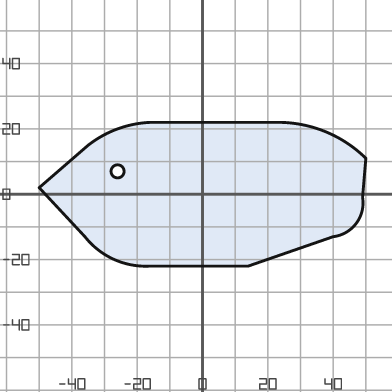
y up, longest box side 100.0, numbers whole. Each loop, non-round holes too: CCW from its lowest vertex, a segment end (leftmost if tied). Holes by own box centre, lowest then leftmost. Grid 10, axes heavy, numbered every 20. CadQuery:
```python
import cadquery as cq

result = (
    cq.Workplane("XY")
    .moveTo(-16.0, -22.0)
    .lineTo(14.0, -22.0)
    .lineTo(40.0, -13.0)
    .threePointArc((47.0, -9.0), (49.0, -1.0))
    .lineTo(50.0, 11.0)
    .threePointArc((38.0, 19.0), (24.0, 22.0))
    .lineTo(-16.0, 22.0)
    .threePointArc((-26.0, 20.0), (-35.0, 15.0))
    .lineTo(-50.0, 2.0)
    .lineTo(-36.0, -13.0)
    .threePointArc((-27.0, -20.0), (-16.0, -22.0))
    .close()
    .moveTo(-26.0, 7.0)
    .circle(2.0)
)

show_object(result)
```